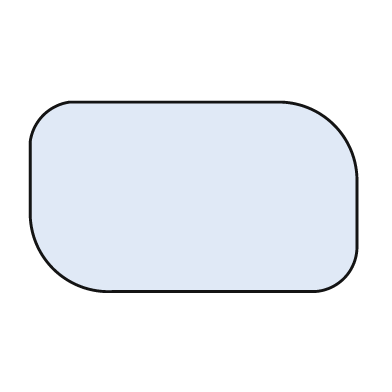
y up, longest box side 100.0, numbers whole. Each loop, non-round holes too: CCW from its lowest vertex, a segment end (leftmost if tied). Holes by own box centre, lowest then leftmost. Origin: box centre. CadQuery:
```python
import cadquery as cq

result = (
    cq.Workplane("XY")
    .moveTo(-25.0, -29.0)
    .lineTo(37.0, -29.0)
    .threePointArc((46.0, -25.0), (50.0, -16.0))
    .lineTo(50.0, 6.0)
    .threePointArc((43.0, 22.0), (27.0, 29.0))
    .lineTo(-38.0, 29.0)
    .threePointArc((-46.0, 25.0), (-50.0, 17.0))
    .lineTo(-50.0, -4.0)
    .threePointArc((-43.0, -22.0), (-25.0, -29.0))
    .close()
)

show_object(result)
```